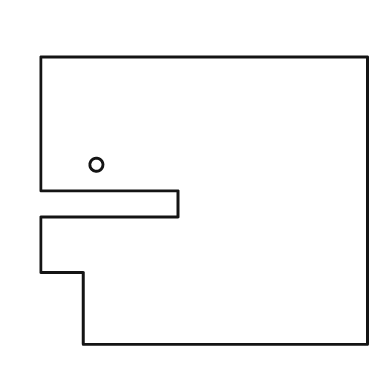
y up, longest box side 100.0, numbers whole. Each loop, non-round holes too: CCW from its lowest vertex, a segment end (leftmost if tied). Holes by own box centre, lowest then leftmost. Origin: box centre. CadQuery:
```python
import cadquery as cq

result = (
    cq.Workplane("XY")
    .moveTo(-37.0, -44.0)
    .lineTo(50.0, -44.0)
    .lineTo(50.0, 44.0)
    .lineTo(-50.0, 44.0)
    .lineTo(-50.0, 3.0)
    .lineTo(-8.0, 3.0)
    .lineTo(-8.0, -5.0)
    .lineTo(-50.0, -5.0)
    .lineTo(-50.0, -22.0)
    .lineTo(-37.0, -22.0)
    .close()
    .moveTo(-33.0, 11.0)
    .circle(2.0)
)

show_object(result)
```